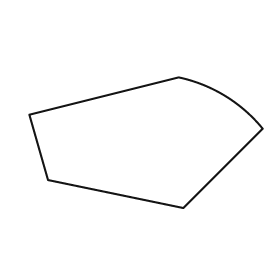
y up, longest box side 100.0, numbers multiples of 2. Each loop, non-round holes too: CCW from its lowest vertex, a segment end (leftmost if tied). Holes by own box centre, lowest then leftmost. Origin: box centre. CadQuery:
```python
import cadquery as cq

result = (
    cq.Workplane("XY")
    .moveTo(16.0, -28.0)
    .lineTo(50.0, 6.0)
    .threePointArc((34.0, 20.0), (14.0, 28.0))
    .lineTo(-50.0, 12.0)
    .lineTo(-42.0, -16.0)
    .close()
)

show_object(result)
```